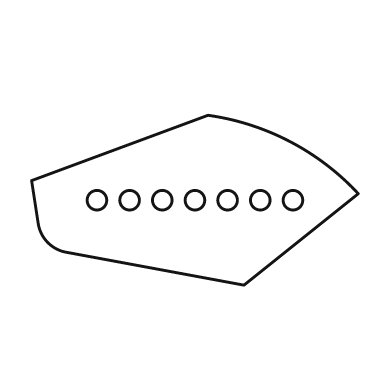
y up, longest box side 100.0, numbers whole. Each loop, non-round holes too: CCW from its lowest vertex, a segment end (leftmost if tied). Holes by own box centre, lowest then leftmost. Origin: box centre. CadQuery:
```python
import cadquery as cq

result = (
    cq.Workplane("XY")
    .moveTo(15.0, -26.0)
    .lineTo(50.0, 2.0)
    .threePointArc((29.0, 18.0), (4.0, 26.0))
    .lineTo(-50.0, 6.0)
    .lineTo(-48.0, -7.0)
    .threePointArc((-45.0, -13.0), (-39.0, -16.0))
    .close()
    .moveTo(-30.0, 0.0)
    .circle(3.0)
    .moveTo(-20.0, 0.0)
    .circle(3.0)
    .moveTo(-10.0, 0.0)
    .circle(3.0)
    .moveTo(0.0, 0.0)
    .circle(3.0)
    .moveTo(10.0, 0.0)
    .circle(3.0)
    .moveTo(20.0, 0.0)
    .circle(3.0)
    .moveTo(30.0, 0.0)
    .circle(3.0)
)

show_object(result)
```